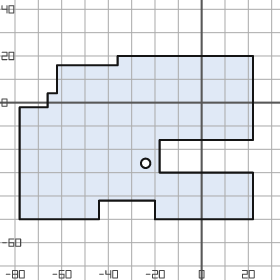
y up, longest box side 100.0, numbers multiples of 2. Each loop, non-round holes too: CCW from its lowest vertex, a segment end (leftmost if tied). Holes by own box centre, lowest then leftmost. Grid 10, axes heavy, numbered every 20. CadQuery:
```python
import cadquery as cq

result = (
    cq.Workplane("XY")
    .moveTo(-78.0, -50.0)
    .lineTo(-44.0, -50.0)
    .lineTo(-44.0, -42.0)
    .lineTo(-20.0, -42.0)
    .lineTo(-20.0, -50.0)
    .lineTo(22.0, -50.0)
    .lineTo(22.0, -30.0)
    .lineTo(-18.0, -30.0)
    .lineTo(-18.0, -16.0)
    .lineTo(22.0, -16.0)
    .lineTo(22.0, 20.0)
    .lineTo(-36.0, 20.0)
    .lineTo(-36.0, 16.0)
    .lineTo(-62.0, 16.0)
    .lineTo(-62.0, 4.0)
    .lineTo(-66.0, 4.0)
    .lineTo(-66.0, -2.0)
    .lineTo(-78.0, -2.0)
    .close()
    .moveTo(-24.0, -26.0)
    .circle(2.0)
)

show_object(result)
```